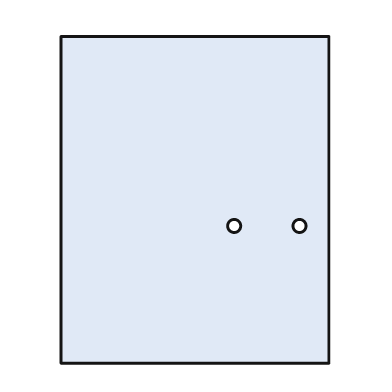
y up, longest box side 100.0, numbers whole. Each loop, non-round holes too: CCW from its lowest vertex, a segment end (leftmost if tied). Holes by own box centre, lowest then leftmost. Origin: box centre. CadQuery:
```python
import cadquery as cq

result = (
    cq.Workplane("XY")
    .moveTo(-41.0, -50.0)
    .lineTo(41.0, -50.0)
    .lineTo(41.0, 50.0)
    .lineTo(-41.0, 50.0)
    .close()
    .moveTo(12.0, -8.0)
    .circle(2.0)
    .moveTo(32.0, -8.0)
    .circle(2.0)
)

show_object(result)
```